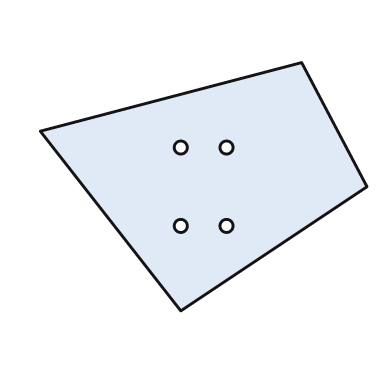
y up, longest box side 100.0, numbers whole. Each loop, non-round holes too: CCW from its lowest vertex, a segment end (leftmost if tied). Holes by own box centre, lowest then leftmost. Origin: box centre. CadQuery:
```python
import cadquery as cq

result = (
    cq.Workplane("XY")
    .moveTo(-7.0, -38.0)
    .lineTo(50.0, 0.0)
    .lineTo(30.0, 38.0)
    .lineTo(-50.0, 17.0)
    .close()
    .moveTo(-7.0, -12.0)
    .circle(2.0)
    .moveTo(7.0, -12.0)
    .circle(2.0)
    .moveTo(-7.0, 12.0)
    .circle(2.0)
    .moveTo(7.0, 12.0)
    .circle(2.0)
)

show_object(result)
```